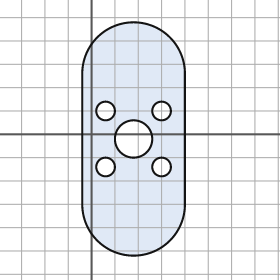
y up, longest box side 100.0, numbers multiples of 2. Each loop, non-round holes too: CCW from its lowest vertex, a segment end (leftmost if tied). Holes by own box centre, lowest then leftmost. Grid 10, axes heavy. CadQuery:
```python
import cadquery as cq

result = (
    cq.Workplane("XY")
    .moveTo(-4.0, -30.0)
    .threePointArc((18.0, -52.0), (40.0, -30.0))
    .lineTo(40.0, 26.0)
    .threePointArc((18.0, 48.0), (-4.0, 26.0))
    .close()
    .moveTo(6.0, -14.0)
    .circle(4.0)
    .moveTo(30.0, -14.0)
    .circle(4.0)
    .moveTo(18.0, -2.0)
    .circle(8.0)
    .moveTo(6.0, 10.0)
    .circle(4.0)
    .moveTo(30.0, 10.0)
    .circle(4.0)
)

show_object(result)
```